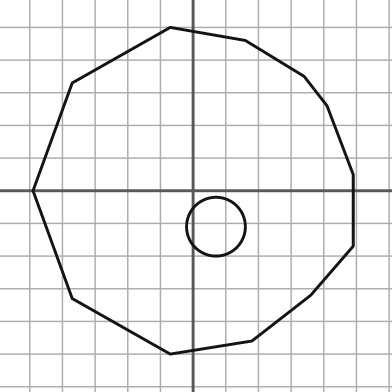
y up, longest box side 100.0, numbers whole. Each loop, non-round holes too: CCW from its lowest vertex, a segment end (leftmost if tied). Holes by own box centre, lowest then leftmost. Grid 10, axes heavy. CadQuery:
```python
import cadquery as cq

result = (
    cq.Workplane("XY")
    .moveTo(-7.0, -50.0)
    .lineTo(18.0, -46.0)
    .lineTo(36.0, -32.0)
    .lineTo(49.0, -17.0)
    .lineTo(49.0, 5.0)
    .lineTo(41.0, 26.0)
    .lineTo(34.0, 35.0)
    .lineTo(16.0, 46.0)
    .lineTo(-7.0, 50.0)
    .lineTo(-37.0, 33.0)
    .lineTo(-49.0, 0.0)
    .lineTo(-37.0, -33.0)
    .close()
    .moveTo(7.0, -11.0)
    .circle(9.0)
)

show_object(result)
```